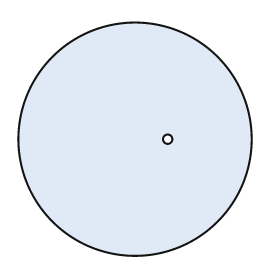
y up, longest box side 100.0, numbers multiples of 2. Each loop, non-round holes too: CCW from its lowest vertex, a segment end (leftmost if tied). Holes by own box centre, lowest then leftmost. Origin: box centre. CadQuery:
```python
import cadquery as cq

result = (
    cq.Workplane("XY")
    .moveTo(0.0, 0.0)
    .circle(50.0)
    .moveTo(14.0, 0.0)
    .circle(2.0)
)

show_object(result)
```